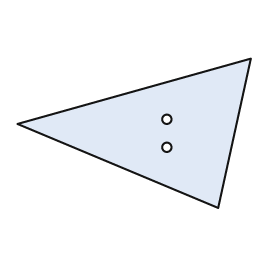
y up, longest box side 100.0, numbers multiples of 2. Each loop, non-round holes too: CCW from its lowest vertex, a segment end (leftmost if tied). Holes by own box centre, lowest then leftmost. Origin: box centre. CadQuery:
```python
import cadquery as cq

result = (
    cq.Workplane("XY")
    .moveTo(36.0, -32.0)
    .lineTo(50.0, 32.0)
    .lineTo(-50.0, 4.0)
    .close()
    .moveTo(14.0, -6.0)
    .circle(2.0)
    .moveTo(14.0, 6.0)
    .circle(2.0)
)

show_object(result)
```